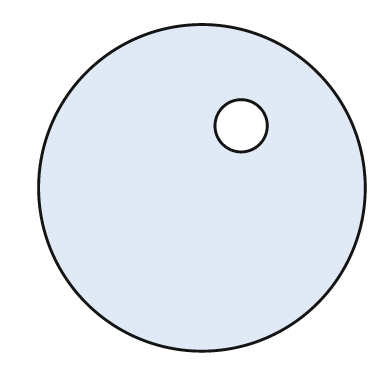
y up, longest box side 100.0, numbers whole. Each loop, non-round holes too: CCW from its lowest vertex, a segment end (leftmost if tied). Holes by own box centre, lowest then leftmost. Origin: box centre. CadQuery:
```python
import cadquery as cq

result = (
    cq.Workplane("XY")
    .moveTo(0.0, 0.0)
    .circle(50.0)
    .moveTo(12.0, 19.0)
    .circle(8.0)
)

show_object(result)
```